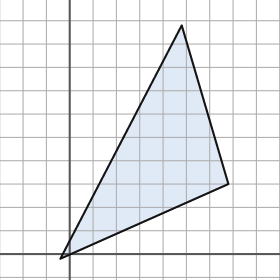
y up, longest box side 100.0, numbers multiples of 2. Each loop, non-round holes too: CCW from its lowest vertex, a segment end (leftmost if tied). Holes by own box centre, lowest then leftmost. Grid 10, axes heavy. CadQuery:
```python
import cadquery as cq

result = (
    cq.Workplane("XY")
    .moveTo(-4.0, -2.0)
    .lineTo(68.0, 30.0)
    .lineTo(48.0, 98.0)
    .close()
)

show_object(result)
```